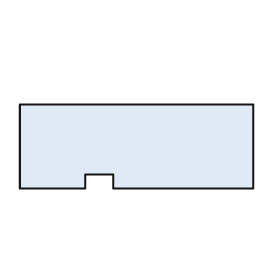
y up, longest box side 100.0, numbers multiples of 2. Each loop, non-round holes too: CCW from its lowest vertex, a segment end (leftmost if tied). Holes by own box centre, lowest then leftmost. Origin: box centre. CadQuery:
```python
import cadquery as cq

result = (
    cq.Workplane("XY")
    .moveTo(-50.0, -18.0)
    .lineTo(-22.0, -18.0)
    .lineTo(-22.0, -12.0)
    .lineTo(-10.0, -12.0)
    .lineTo(-10.0, -18.0)
    .lineTo(50.0, -18.0)
    .lineTo(50.0, 18.0)
    .lineTo(-50.0, 18.0)
    .close()
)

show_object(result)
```